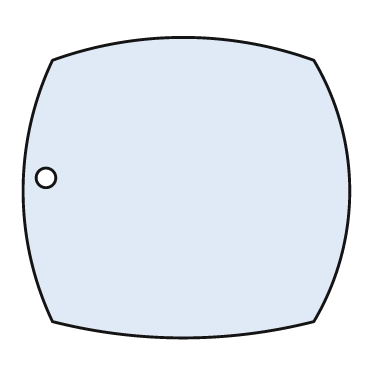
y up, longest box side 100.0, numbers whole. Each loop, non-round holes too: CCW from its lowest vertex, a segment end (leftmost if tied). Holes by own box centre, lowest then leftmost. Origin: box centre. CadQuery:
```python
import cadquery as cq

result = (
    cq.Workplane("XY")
    .moveTo(-41.0, -41.0)
    .threePointArc((-1.0, -46.0), (39.0, -41.0))
    .threePointArc((50.0, -1.0), (39.0, 39.0))
    .threePointArc((-1.0, 46.0), (-41.0, 39.0))
    .threePointArc((-50.0, -1.0), (-41.0, -41.0))
    .close()
    .moveTo(-43.0, 3.0)
    .circle(3.0)
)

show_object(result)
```